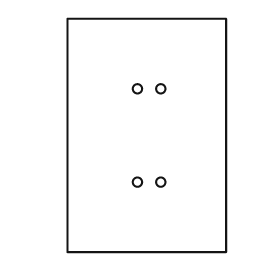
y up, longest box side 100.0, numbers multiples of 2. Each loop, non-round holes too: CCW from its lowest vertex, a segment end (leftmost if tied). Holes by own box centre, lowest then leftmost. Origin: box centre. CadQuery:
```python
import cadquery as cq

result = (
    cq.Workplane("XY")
    .moveTo(-34.0, -50.0)
    .lineTo(34.0, -50.0)
    .lineTo(34.0, 50.0)
    .lineTo(-34.0, 50.0)
    .close()
    .moveTo(-4.0, -20.0)
    .circle(2.0)
    .moveTo(6.0, -20.0)
    .circle(2.0)
    .moveTo(-4.0, 20.0)
    .circle(2.0)
    .moveTo(6.0, 20.0)
    .circle(2.0)
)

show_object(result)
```